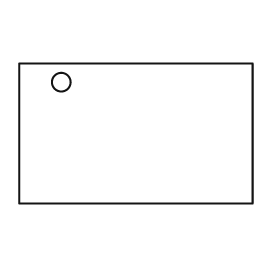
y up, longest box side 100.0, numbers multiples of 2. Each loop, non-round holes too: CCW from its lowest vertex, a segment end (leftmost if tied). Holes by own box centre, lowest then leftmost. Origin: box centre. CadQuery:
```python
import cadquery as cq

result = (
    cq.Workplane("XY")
    .moveTo(-50.0, -30.0)
    .lineTo(50.0, -30.0)
    .lineTo(50.0, 30.0)
    .lineTo(-50.0, 30.0)
    .close()
    .moveTo(-32.0, 22.0)
    .circle(4.0)
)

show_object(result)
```